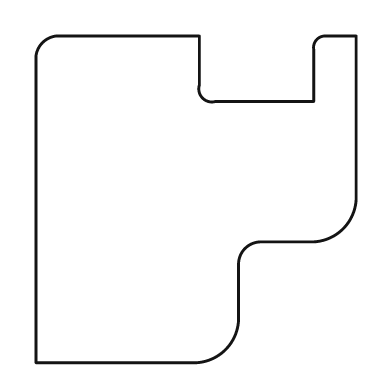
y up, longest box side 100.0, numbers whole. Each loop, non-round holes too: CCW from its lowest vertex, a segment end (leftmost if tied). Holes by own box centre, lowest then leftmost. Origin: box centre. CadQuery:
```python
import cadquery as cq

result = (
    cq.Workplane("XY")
    .moveTo(-49.0, -50.0)
    .lineTo(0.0, -50.0)
    .threePointArc((9.0, -46.0), (13.0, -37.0))
    .lineTo(13.0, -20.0)
    .threePointArc((15.0, -15.0), (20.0, -13.0))
    .lineTo(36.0, -13.0)
    .threePointArc((45.0, -9.0), (49.0, 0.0))
    .lineTo(49.0, 50.0)
    .lineTo(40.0, 50.0)
    .threePointArc((37.0, 49.0), (36.0, 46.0))
    .lineTo(36.0, 30.0)
    .lineTo(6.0, 30.0)
    .threePointArc((2.0, 31.0), (1.0, 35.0))
    .lineTo(1.0, 50.0)
    .lineTo(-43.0, 50.0)
    .threePointArc((-47.0, 48.0), (-49.0, 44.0))
    .close()
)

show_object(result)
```